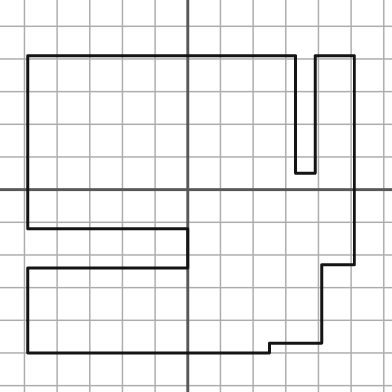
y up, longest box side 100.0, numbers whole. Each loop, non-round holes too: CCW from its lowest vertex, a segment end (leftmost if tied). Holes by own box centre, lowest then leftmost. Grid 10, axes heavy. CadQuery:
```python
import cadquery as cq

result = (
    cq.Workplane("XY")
    .moveTo(-49.0, -50.0)
    .lineTo(25.0, -50.0)
    .lineTo(25.0, -47.0)
    .lineTo(41.0, -47.0)
    .lineTo(41.0, -23.0)
    .lineTo(51.0, -23.0)
    .lineTo(51.0, 41.0)
    .lineTo(39.0, 41.0)
    .lineTo(39.0, 5.0)
    .lineTo(33.0, 5.0)
    .lineTo(33.0, 41.0)
    .lineTo(-49.0, 41.0)
    .lineTo(-49.0, -12.0)
    .lineTo(0.0, -12.0)
    .lineTo(0.0, -24.0)
    .lineTo(-49.0, -24.0)
    .close()
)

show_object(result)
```